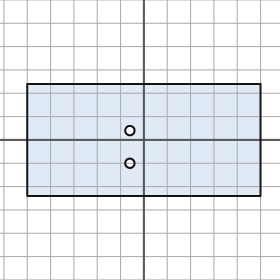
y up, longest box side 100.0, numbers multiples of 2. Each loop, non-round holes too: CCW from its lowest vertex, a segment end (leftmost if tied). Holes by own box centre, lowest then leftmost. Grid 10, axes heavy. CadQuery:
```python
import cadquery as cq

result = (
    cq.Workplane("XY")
    .moveTo(-50.0, -24.0)
    .lineTo(50.0, -24.0)
    .lineTo(50.0, 24.0)
    .lineTo(-50.0, 24.0)
    .close()
    .moveTo(-6.0, -10.0)
    .circle(2.0)
    .moveTo(-6.0, 4.0)
    .circle(2.0)
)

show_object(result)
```